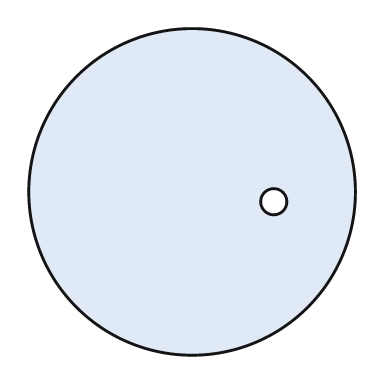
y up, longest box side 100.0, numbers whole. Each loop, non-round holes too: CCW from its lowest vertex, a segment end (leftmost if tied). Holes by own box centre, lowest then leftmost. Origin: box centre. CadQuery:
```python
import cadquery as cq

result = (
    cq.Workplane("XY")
    .moveTo(0.0, 0.0)
    .circle(50.0)
    .moveTo(25.0, -3.0)
    .circle(4.0)
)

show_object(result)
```